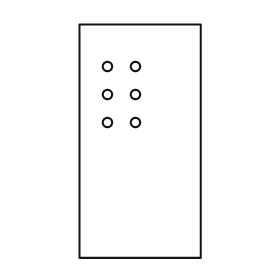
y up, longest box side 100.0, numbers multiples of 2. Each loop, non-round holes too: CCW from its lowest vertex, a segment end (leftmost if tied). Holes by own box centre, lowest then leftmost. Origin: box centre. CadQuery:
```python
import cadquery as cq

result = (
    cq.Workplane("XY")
    .moveTo(-26.0, -50.0)
    .lineTo(26.0, -50.0)
    .lineTo(26.0, 50.0)
    .lineTo(-26.0, 50.0)
    .close()
    .moveTo(-14.0, 8.0)
    .circle(2.0)
    .moveTo(-2.0, 8.0)
    .circle(2.0)
    .moveTo(-14.0, 20.0)
    .circle(2.0)
    .moveTo(-2.0, 20.0)
    .circle(2.0)
    .moveTo(-14.0, 32.0)
    .circle(2.0)
    .moveTo(-2.0, 32.0)
    .circle(2.0)
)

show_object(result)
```